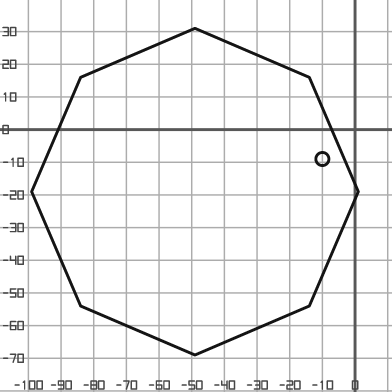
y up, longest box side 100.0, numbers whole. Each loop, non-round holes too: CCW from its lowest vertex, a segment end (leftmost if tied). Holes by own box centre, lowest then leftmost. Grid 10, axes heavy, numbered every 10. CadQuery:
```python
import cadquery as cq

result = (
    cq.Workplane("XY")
    .moveTo(-49.0, -69.0)
    .lineTo(-14.0, -54.0)
    .lineTo(1.0, -19.0)
    .lineTo(-14.0, 16.0)
    .lineTo(-49.0, 31.0)
    .lineTo(-84.0, 16.0)
    .lineTo(-99.0, -19.0)
    .lineTo(-84.0, -54.0)
    .close()
    .moveTo(-10.0, -9.0)
    .circle(2.0)
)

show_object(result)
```